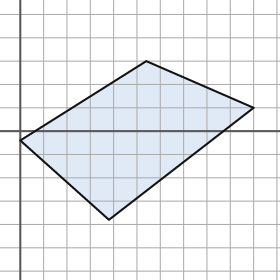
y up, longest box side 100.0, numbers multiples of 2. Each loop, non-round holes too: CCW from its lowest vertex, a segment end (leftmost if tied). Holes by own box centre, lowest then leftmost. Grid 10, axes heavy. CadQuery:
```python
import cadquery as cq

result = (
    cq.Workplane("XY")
    .moveTo(38.0, -38.0)
    .lineTo(100.0, 10.0)
    .lineTo(54.0, 30.0)
    .lineTo(0.0, -4.0)
    .close()
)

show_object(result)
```